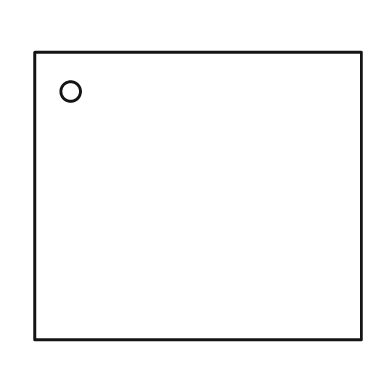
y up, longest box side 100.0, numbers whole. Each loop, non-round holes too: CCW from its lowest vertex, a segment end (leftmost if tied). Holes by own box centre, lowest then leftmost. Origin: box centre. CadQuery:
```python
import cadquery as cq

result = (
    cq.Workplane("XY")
    .moveTo(-50.0, -44.0)
    .lineTo(50.0, -44.0)
    .lineTo(50.0, 44.0)
    .lineTo(-50.0, 44.0)
    .close()
    .moveTo(-39.0, 32.0)
    .circle(3.0)
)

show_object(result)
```